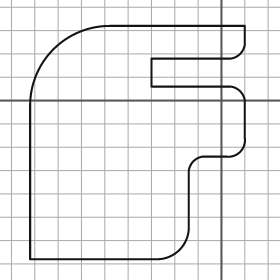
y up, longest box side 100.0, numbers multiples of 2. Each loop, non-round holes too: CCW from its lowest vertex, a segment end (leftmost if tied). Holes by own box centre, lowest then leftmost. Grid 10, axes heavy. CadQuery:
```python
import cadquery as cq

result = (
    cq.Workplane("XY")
    .moveTo(-82.0, -68.0)
    .lineTo(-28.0, -68.0)
    .threePointArc((-18.0, -64.0), (-14.0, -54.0))
    .lineTo(-14.0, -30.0)
    .threePointArc((-12.0, -26.0), (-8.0, -24.0))
    .lineTo(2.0, -24.0)
    .threePointArc((8.0, -22.0), (10.0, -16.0))
    .lineTo(10.0, 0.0)
    .threePointArc((8.0, 4.0), (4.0, 6.0))
    .lineTo(-30.0, 6.0)
    .lineTo(-30.0, 18.0)
    .lineTo(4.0, 18.0)
    .threePointArc((8.0, 20.0), (10.0, 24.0))
    .lineTo(10.0, 32.0)
    .lineTo(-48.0, 32.0)
    .threePointArc((-72.0, 22.0), (-82.0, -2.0))
    .close()
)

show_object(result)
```